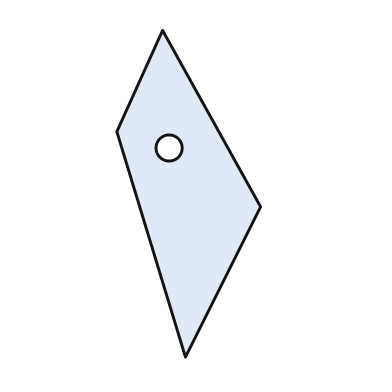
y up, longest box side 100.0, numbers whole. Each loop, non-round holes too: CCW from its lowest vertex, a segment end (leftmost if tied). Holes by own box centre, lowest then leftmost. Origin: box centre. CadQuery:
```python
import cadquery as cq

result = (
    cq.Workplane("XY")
    .moveTo(-1.0, -50.0)
    .lineTo(22.0, -4.0)
    .lineTo(-8.0, 50.0)
    .lineTo(-22.0, 19.0)
    .close()
    .moveTo(-6.0, 14.0)
    .circle(4.0)
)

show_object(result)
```